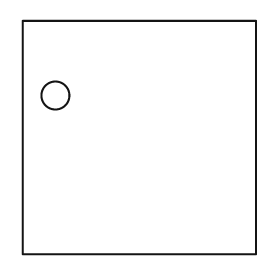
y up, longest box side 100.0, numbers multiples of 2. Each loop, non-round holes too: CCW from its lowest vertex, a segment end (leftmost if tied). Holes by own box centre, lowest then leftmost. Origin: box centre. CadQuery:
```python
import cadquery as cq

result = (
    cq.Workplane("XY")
    .moveTo(-50.0, -50.0)
    .lineTo(50.0, -50.0)
    .lineTo(50.0, 50.0)
    .lineTo(-50.0, 50.0)
    .close()
    .moveTo(-36.0, 18.0)
    .circle(6.0)
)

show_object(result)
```